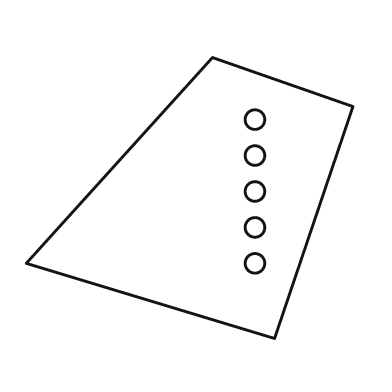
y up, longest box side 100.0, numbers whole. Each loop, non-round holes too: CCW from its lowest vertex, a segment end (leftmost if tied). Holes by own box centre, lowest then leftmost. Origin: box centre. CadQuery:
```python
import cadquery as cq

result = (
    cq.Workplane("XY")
    .moveTo(26.0, -43.0)
    .lineTo(50.0, 28.0)
    .lineTo(7.0, 43.0)
    .lineTo(-50.0, -20.0)
    .close()
    .moveTo(20.0, -20.0)
    .circle(3.0)
    .moveTo(20.0, -9.0)
    .circle(3.0)
    .moveTo(20.0, 2.0)
    .circle(3.0)
    .moveTo(20.0, 13.0)
    .circle(3.0)
    .moveTo(20.0, 24.0)
    .circle(3.0)
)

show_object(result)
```